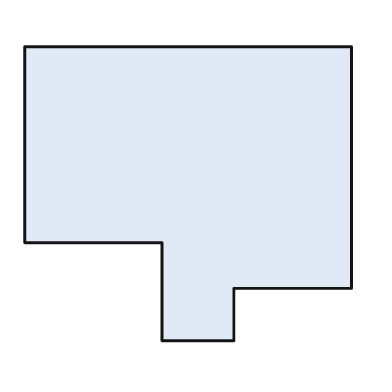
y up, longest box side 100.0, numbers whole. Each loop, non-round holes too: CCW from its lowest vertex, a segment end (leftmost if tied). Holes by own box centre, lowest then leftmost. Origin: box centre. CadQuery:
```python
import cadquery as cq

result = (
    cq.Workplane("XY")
    .moveTo(-8.0, -45.0)
    .lineTo(14.0, -45.0)
    .lineTo(14.0, -29.0)
    .lineTo(50.0, -29.0)
    .lineTo(50.0, 45.0)
    .lineTo(-50.0, 45.0)
    .lineTo(-50.0, -15.0)
    .lineTo(-8.0, -15.0)
    .close()
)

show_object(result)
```